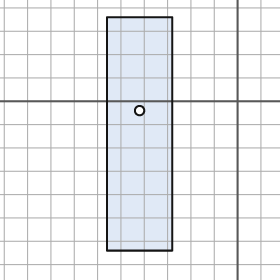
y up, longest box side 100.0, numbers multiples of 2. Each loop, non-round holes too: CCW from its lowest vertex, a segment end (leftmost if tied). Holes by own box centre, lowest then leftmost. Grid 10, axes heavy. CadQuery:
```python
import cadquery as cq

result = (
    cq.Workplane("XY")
    .moveTo(-56.0, -64.0)
    .lineTo(-28.0, -64.0)
    .lineTo(-28.0, 36.0)
    .lineTo(-56.0, 36.0)
    .close()
    .moveTo(-42.0, -4.0)
    .circle(2.0)
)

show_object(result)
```